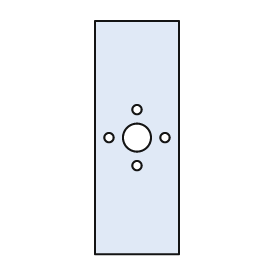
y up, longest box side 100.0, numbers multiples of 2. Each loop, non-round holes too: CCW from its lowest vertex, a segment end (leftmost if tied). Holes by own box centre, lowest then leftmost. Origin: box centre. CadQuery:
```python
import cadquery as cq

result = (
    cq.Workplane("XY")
    .moveTo(-18.0, -50.0)
    .lineTo(18.0, -50.0)
    .lineTo(18.0, 50.0)
    .lineTo(-18.0, 50.0)
    .close()
    .moveTo(0.0, -12.0)
    .circle(2.0)
    .moveTo(-12.0, 0.0)
    .circle(2.0)
    .moveTo(0.0, 0.0)
    .circle(6.0)
    .moveTo(12.0, 0.0)
    .circle(2.0)
    .moveTo(0.0, 12.0)
    .circle(2.0)
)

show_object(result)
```